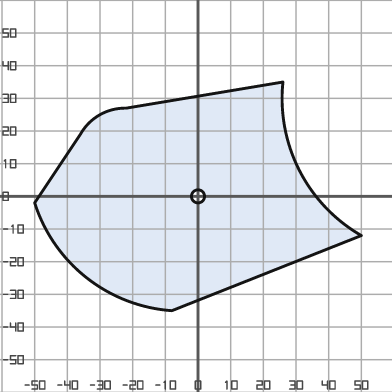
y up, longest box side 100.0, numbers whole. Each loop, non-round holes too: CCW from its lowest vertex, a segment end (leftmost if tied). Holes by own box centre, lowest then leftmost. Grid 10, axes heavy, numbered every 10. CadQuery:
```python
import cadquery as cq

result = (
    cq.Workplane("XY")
    .moveTo(-8.0, -35.0)
    .lineTo(50.0, -12.0)
    .threePointArc((31.0, 8.0), (26.0, 35.0))
    .lineTo(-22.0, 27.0)
    .threePointArc((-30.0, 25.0), (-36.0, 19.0))
    .lineTo(-50.0, -2.0)
    .threePointArc((-34.0, -25.0), (-8.0, -35.0))
    .close()
    .moveTo(0.0, 0.0)
    .circle(2.0)
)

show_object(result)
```